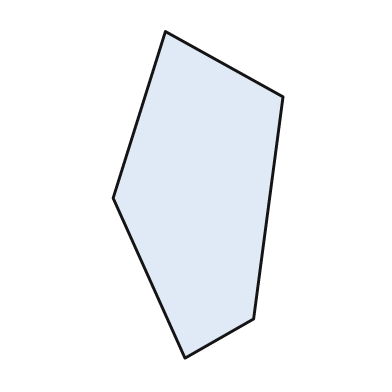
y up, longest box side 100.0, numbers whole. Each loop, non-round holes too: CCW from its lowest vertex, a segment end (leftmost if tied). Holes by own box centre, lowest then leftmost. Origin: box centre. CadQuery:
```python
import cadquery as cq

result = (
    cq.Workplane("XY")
    .moveTo(-4.0, -50.0)
    .lineTo(17.0, -38.0)
    .lineTo(26.0, 30.0)
    .lineTo(-10.0, 50.0)
    .lineTo(-26.0, -1.0)
    .close()
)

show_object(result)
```